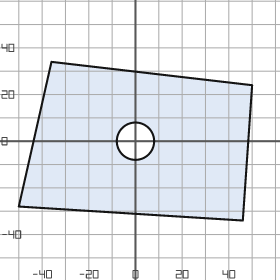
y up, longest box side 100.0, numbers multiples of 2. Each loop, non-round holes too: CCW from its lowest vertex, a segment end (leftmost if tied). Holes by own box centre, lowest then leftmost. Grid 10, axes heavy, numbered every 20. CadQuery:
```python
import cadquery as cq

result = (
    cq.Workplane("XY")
    .moveTo(46.0, -34.0)
    .lineTo(50.0, 24.0)
    .lineTo(-36.0, 34.0)
    .lineTo(-50.0, -28.0)
    .close()
    .moveTo(0.0, 0.0)
    .circle(8.0)
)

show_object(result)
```